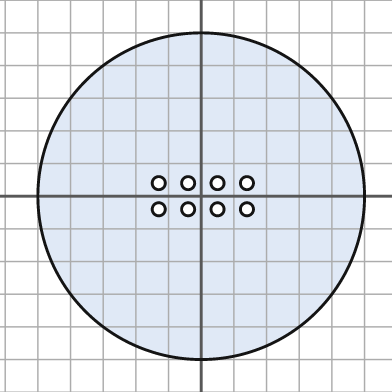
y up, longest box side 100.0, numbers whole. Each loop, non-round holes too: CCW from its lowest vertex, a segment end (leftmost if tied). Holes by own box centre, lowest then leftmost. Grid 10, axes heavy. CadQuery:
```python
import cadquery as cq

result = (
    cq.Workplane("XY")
    .moveTo(0.0, 0.0)
    .circle(50.0)
    .moveTo(-13.0, -4.0)
    .circle(2.0)
    .moveTo(-4.0, -4.0)
    .circle(2.0)
    .moveTo(5.0, -4.0)
    .circle(2.0)
    .moveTo(14.0, -4.0)
    .circle(2.0)
    .moveTo(-13.0, 4.0)
    .circle(2.0)
    .moveTo(-4.0, 4.0)
    .circle(2.0)
    .moveTo(5.0, 4.0)
    .circle(2.0)
    .moveTo(14.0, 4.0)
    .circle(2.0)
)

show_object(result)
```